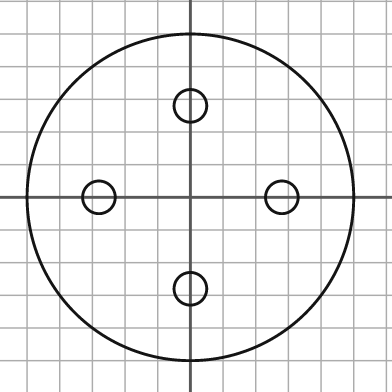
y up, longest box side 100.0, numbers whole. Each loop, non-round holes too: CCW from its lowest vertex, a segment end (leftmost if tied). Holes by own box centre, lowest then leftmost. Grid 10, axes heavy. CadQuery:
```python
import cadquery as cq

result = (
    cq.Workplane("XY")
    .moveTo(0.0, 0.0)
    .circle(50.0)
    .moveTo(0.0, -28.0)
    .circle(5.0)
    .moveTo(-28.0, 0.0)
    .circle(5.0)
    .moveTo(28.0, 0.0)
    .circle(5.0)
    .moveTo(0.0, 28.0)
    .circle(5.0)
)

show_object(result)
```